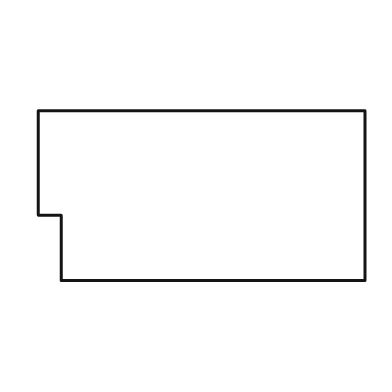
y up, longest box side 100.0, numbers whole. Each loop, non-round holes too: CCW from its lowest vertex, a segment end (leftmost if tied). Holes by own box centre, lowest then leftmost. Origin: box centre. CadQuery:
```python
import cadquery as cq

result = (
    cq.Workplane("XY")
    .moveTo(-43.0, -26.0)
    .lineTo(50.0, -26.0)
    .lineTo(50.0, 26.0)
    .lineTo(-50.0, 26.0)
    .lineTo(-50.0, -6.0)
    .lineTo(-43.0, -6.0)
    .close()
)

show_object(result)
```